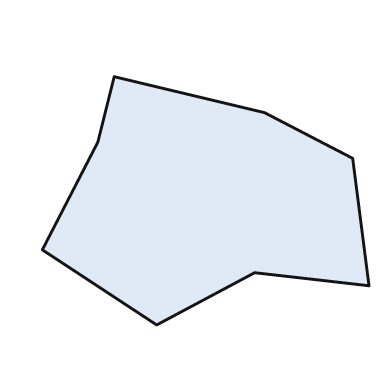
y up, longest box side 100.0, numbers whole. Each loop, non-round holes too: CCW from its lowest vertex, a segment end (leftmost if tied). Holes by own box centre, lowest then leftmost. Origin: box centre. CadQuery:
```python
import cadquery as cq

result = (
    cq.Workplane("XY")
    .moveTo(-15.0, -38.0)
    .lineTo(15.0, -22.0)
    .lineTo(50.0, -26.0)
    .lineTo(45.0, 13.0)
    .lineTo(18.0, 27.0)
    .lineTo(-28.0, 38.0)
    .lineTo(-33.0, 18.0)
    .lineTo(-50.0, -15.0)
    .close()
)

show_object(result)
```